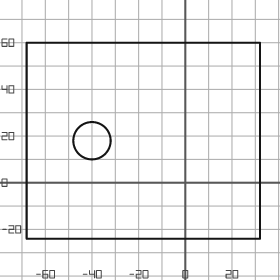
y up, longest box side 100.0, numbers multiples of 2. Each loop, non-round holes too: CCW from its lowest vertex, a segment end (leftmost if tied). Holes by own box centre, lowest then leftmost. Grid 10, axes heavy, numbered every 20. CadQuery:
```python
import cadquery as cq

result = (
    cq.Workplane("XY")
    .moveTo(-68.0, -24.0)
    .lineTo(32.0, -24.0)
    .lineTo(32.0, 60.0)
    .lineTo(-68.0, 60.0)
    .close()
    .moveTo(-40.0, 18.0)
    .circle(8.0)
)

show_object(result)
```